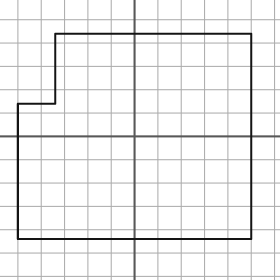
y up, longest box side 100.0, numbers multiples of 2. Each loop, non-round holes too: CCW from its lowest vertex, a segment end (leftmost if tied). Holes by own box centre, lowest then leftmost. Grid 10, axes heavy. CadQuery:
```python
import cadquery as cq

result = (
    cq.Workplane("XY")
    .moveTo(-50.0, -44.0)
    .lineTo(50.0, -44.0)
    .lineTo(50.0, 44.0)
    .lineTo(-34.0, 44.0)
    .lineTo(-34.0, 14.0)
    .lineTo(-50.0, 14.0)
    .close()
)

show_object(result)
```